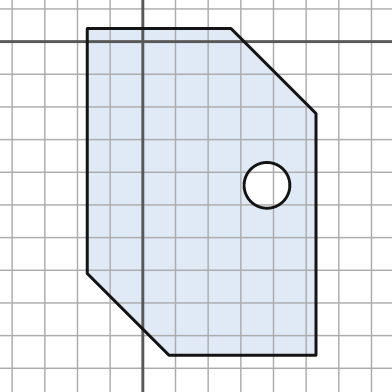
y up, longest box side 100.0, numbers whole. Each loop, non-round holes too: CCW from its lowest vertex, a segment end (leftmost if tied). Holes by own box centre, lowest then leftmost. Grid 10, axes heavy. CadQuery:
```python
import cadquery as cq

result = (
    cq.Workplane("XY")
    .moveTo(8.0, -96.0)
    .lineTo(53.0, -96.0)
    .lineTo(53.0, -22.0)
    .lineTo(27.0, 4.0)
    .lineTo(-17.0, 4.0)
    .lineTo(-17.0, -71.0)
    .close()
    .moveTo(38.0, -44.0)
    .circle(7.0)
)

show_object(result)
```